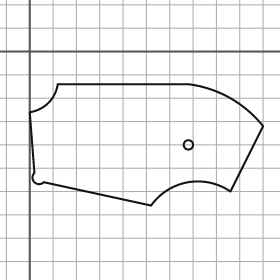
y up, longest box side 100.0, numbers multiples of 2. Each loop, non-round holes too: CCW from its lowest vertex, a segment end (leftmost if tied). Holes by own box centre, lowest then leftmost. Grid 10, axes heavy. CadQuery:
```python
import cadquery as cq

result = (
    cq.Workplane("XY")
    .moveTo(52.0, -66.0)
    .threePointArc((68.0, -56.0), (86.0, -60.0))
    .lineTo(100.0, -32.0)
    .threePointArc((86.0, -20.0), (68.0, -14.0))
    .lineTo(12.0, -14.0)
    .threePointArc((8.0, -22.0), (0.0, -26.0))
    .lineTo(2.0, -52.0)
    .threePointArc((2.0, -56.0), (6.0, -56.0))
    .close()
    .moveTo(68.0, -40.0)
    .circle(2.0)
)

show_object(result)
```